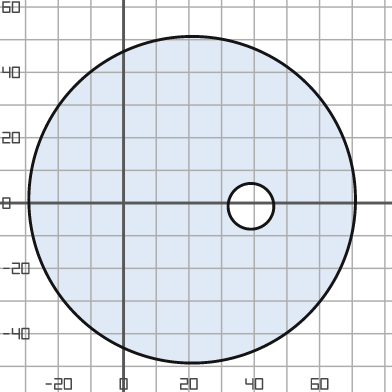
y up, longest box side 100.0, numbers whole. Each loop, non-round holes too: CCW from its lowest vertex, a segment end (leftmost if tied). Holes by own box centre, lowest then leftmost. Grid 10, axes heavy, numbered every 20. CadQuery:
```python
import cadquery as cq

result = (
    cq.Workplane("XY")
    .moveTo(21.0, 1.0)
    .circle(50.0)
    .moveTo(39.0, -1.0)
    .circle(7.0)
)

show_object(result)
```